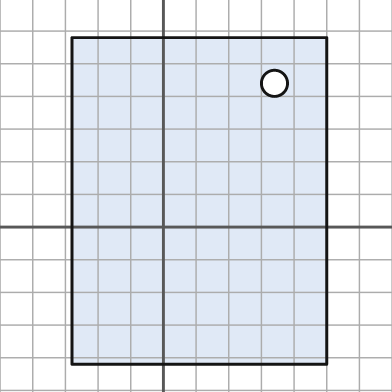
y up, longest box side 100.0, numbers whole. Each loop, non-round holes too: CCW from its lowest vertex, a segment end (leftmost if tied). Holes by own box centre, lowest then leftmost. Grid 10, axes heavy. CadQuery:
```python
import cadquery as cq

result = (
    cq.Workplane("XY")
    .moveTo(-28.0, -42.0)
    .lineTo(50.0, -42.0)
    .lineTo(50.0, 58.0)
    .lineTo(-28.0, 58.0)
    .close()
    .moveTo(34.0, 44.0)
    .circle(4.0)
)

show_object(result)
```